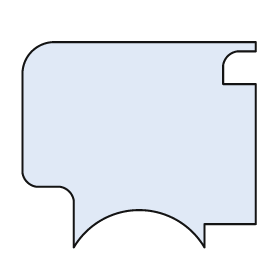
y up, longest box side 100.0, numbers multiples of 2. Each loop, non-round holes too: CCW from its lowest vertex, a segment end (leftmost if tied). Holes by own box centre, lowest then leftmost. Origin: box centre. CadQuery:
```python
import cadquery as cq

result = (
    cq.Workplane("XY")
    .moveTo(-28.0, -44.0)
    .threePointArc((0.0, -28.0), (28.0, -44.0))
    .lineTo(28.0, -34.0)
    .lineTo(50.0, -34.0)
    .lineTo(50.0, 26.0)
    .lineTo(36.0, 26.0)
    .lineTo(36.0, 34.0)
    .threePointArc((38.0, 38.0), (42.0, 40.0))
    .lineTo(50.0, 40.0)
    .lineTo(50.0, 44.0)
    .lineTo(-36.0, 44.0)
    .threePointArc((-46.0, 40.0), (-50.0, 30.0))
    .lineTo(-50.0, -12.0)
    .threePointArc((-48.0, -16.0), (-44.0, -18.0))
    .lineTo(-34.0, -18.0)
    .threePointArc((-30.0, -20.0), (-28.0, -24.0))
    .close()
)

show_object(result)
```